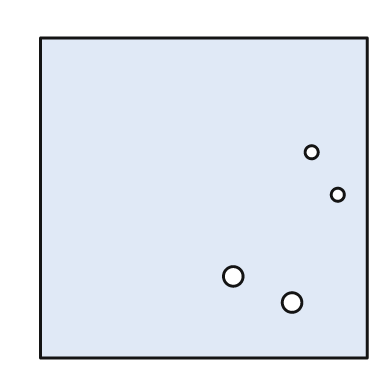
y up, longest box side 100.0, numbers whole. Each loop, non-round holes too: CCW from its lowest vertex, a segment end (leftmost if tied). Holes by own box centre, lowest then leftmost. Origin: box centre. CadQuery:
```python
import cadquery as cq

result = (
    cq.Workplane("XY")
    .moveTo(-50.0, -49.0)
    .lineTo(50.0, -49.0)
    .lineTo(50.0, 49.0)
    .lineTo(-50.0, 49.0)
    .close()
    .moveTo(27.0, -32.0)
    .circle(3.0)
    .moveTo(9.0, -24.0)
    .circle(3.0)
    .moveTo(41.0, 1.0)
    .circle(2.0)
    .moveTo(33.0, 14.0)
    .circle(2.0)
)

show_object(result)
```